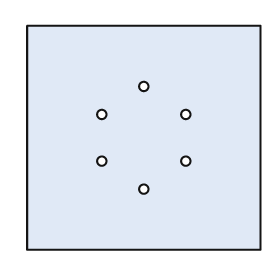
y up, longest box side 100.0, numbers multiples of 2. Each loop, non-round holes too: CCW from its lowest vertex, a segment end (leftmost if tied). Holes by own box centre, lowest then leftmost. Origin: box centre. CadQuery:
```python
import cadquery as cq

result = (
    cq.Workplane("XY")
    .moveTo(-50.0, -48.0)
    .lineTo(50.0, -48.0)
    .lineTo(50.0, 48.0)
    .lineTo(-50.0, 48.0)
    .close()
    .moveTo(0.0, -22.0)
    .circle(2.0)
    .moveTo(-18.0, -10.0)
    .circle(2.0)
    .moveTo(18.0, -10.0)
    .circle(2.0)
    .moveTo(-18.0, 10.0)
    .circle(2.0)
    .moveTo(18.0, 10.0)
    .circle(2.0)
    .moveTo(0.0, 22.0)
    .circle(2.0)
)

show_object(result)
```